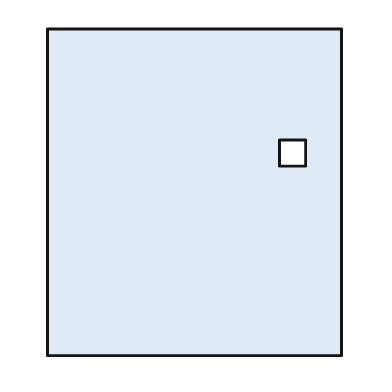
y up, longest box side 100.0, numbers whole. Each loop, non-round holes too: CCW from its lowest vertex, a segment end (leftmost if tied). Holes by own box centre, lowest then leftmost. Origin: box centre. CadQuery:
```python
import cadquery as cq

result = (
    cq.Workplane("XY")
    .moveTo(-45.0, -50.0)
    .lineTo(45.0, -50.0)
    .lineTo(45.0, 50.0)
    .lineTo(-45.0, 50.0)
    .close()
    .moveTo(26.0, 8.0)
    .lineTo(34.0, 8.0)
    .lineTo(34.0, 16.0)
    .lineTo(26.0, 16.0)
    .close()
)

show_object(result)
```